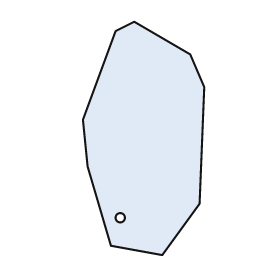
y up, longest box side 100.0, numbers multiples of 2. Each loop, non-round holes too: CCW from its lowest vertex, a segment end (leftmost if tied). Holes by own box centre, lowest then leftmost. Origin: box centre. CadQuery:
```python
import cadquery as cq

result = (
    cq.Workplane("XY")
    .moveTo(8.0, -50.0)
    .lineTo(24.0, -28.0)
    .lineTo(26.0, 22.0)
    .lineTo(20.0, 36.0)
    .lineTo(-4.0, 50.0)
    .lineTo(-12.0, 46.0)
    .lineTo(-26.0, 8.0)
    .lineTo(-24.0, -12.0)
    .lineTo(-14.0, -46.0)
    .close()
    .moveTo(-10.0, -34.0)
    .circle(2.0)
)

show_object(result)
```